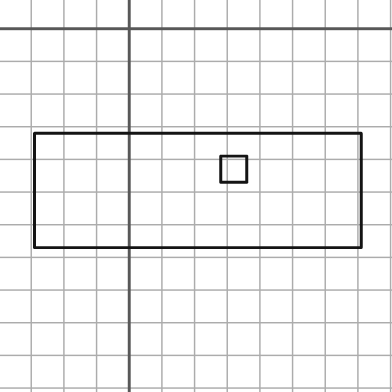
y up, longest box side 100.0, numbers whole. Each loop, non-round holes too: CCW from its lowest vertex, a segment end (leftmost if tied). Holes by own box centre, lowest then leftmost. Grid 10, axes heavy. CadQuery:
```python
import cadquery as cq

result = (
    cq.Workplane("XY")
    .moveTo(-29.0, -67.0)
    .lineTo(71.0, -67.0)
    .lineTo(71.0, -32.0)
    .lineTo(-29.0, -32.0)
    .close()
    .moveTo(28.0, -47.0)
    .lineTo(36.0, -47.0)
    .lineTo(36.0, -39.0)
    .lineTo(28.0, -39.0)
    .close()
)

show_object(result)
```